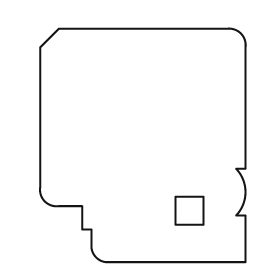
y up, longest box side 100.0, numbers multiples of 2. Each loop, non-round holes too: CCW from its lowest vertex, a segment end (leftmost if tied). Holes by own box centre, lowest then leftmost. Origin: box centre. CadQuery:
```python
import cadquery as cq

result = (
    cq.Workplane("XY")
    .moveTo(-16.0, -50.0)
    .lineTo(44.0, -50.0)
    .lineTo(44.0, -30.0)
    .lineTo(40.0, -30.0)
    .threePointArc((44.0, -20.0), (40.0, -10.0))
    .lineTo(44.0, -10.0)
    .lineTo(44.0, 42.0)
    .threePointArc((42.0, 48.0), (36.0, 50.0))
    .lineTo(-36.0, 50.0)
    .lineTo(-44.0, 42.0)
    .lineTo(-44.0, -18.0)
    .threePointArc((-42.0, -24.0), (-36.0, -26.0))
    .lineTo(-26.0, -26.0)
    .lineTo(-26.0, -36.0)
    .lineTo(-22.0, -36.0)
    .lineTo(-22.0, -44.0)
    .threePointArc((-20.0, -48.0), (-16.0, -50.0))
    .close()
    .moveTo(14.0, -34.0)
    .lineTo(26.0, -34.0)
    .lineTo(26.0, -22.0)
    .lineTo(14.0, -22.0)
    .close()
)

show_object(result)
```